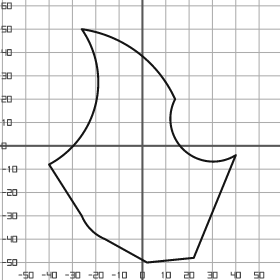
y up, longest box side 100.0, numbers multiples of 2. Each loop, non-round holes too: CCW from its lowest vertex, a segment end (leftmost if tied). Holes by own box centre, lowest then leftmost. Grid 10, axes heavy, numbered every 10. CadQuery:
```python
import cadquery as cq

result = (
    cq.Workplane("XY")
    .moveTo(2.0, -50.0)
    .lineTo(22.0, -48.0)
    .lineTo(40.0, -4.0)
    .threePointArc((18.0, -2.0), (14.0, 20.0))
    .threePointArc((-2.0, 40.0), (-26.0, 50.0))
    .threePointArc((-20.0, 18.0), (-40.0, -8.0))
    .lineTo(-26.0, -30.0)
    .threePointArc((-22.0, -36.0), (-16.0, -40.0))
    .close()
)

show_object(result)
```